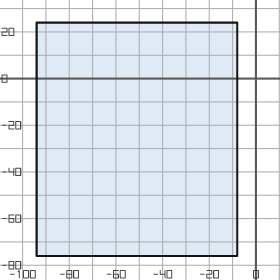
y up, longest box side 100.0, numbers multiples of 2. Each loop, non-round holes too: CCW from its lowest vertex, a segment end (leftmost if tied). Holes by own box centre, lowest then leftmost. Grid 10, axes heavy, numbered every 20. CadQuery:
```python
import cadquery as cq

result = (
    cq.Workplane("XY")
    .moveTo(-94.0, -76.0)
    .lineTo(-8.0, -76.0)
    .lineTo(-8.0, 24.0)
    .lineTo(-94.0, 24.0)
    .close()
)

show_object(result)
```